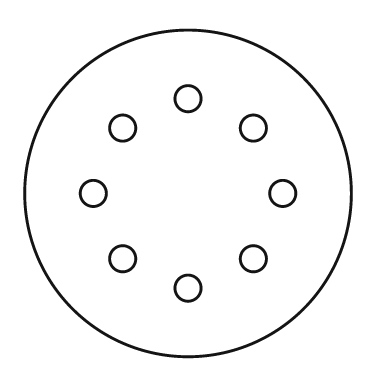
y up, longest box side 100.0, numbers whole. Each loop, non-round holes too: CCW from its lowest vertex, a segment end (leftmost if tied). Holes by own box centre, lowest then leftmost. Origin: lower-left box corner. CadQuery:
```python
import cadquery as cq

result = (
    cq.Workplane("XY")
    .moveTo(50.0, 50.0)
    .circle(50.0)
    .moveTo(50.0, 21.0)
    .circle(4.0)
    .moveTo(30.0, 30.0)
    .circle(4.0)
    .moveTo(70.0, 30.0)
    .circle(4.0)
    .moveTo(21.0, 50.0)
    .circle(4.0)
    .moveTo(79.0, 50.0)
    .circle(4.0)
    .moveTo(30.0, 70.0)
    .circle(4.0)
    .moveTo(70.0, 70.0)
    .circle(4.0)
    .moveTo(50.0, 79.0)
    .circle(4.0)
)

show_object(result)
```